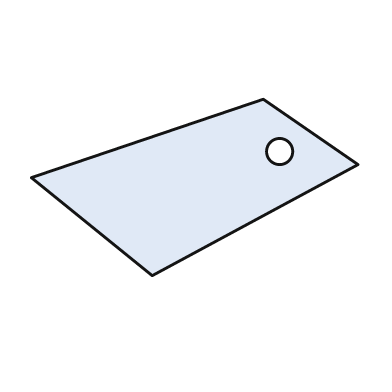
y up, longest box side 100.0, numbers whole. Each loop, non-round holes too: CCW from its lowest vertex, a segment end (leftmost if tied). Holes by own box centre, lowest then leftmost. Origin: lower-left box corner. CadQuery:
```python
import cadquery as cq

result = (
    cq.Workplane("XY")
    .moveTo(37.0, 0.0)
    .lineTo(100.0, 34.0)
    .lineTo(71.0, 54.0)
    .lineTo(0.0, 30.0)
    .close()
    .moveTo(76.0, 38.0)
    .circle(4.0)
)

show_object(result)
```